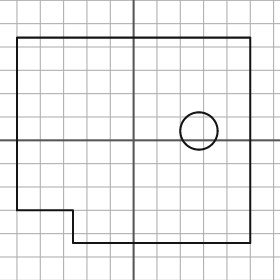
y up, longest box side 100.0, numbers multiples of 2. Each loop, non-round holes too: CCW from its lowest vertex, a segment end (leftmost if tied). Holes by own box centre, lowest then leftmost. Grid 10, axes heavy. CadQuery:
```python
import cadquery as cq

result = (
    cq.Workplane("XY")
    .moveTo(-26.0, -44.0)
    .lineTo(50.0, -44.0)
    .lineTo(50.0, 44.0)
    .lineTo(-50.0, 44.0)
    .lineTo(-50.0, -30.0)
    .lineTo(-26.0, -30.0)
    .close()
    .moveTo(28.0, 4.0)
    .circle(8.0)
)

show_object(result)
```